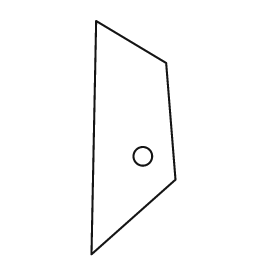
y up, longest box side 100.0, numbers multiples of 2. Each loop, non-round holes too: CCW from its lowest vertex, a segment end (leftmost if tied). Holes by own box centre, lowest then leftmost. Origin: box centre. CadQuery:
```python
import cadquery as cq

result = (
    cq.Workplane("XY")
    .moveTo(-18.0, -50.0)
    .lineTo(18.0, -18.0)
    .lineTo(14.0, 32.0)
    .lineTo(-16.0, 50.0)
    .close()
    .moveTo(4.0, -8.0)
    .circle(4.0)
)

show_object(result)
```